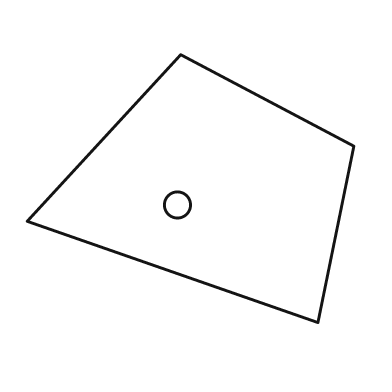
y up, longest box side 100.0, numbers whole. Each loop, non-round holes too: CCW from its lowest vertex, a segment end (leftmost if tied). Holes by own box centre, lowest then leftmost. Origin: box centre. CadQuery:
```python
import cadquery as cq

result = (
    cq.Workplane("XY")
    .moveTo(39.0, -41.0)
    .lineTo(50.0, 13.0)
    .lineTo(-3.0, 41.0)
    .lineTo(-50.0, -10.0)
    .close()
    .moveTo(-4.0, -5.0)
    .circle(4.0)
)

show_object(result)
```